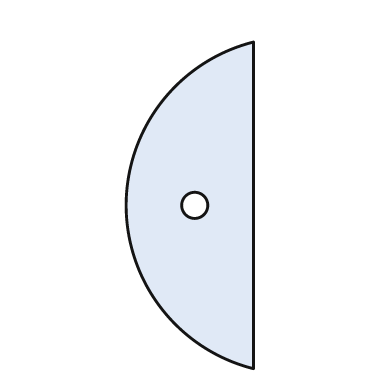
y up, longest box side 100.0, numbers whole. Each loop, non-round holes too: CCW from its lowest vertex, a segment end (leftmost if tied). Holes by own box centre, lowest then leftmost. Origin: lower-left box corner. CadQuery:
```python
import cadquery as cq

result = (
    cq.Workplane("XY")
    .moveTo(39.0, 0.0)
    .lineTo(39.0, 100.0)
    .threePointArc((0.0, 50.0), (39.0, 0.0))
    .close()
    .moveTo(21.0, 50.0)
    .circle(4.0)
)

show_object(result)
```